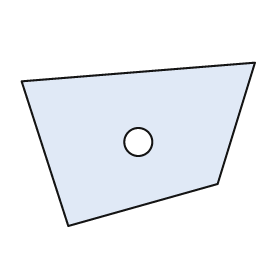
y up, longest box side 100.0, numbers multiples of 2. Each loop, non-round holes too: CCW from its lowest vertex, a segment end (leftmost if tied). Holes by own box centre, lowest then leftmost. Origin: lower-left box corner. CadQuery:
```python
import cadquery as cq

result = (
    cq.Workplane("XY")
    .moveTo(20.0, 0.0)
    .lineTo(84.0, 18.0)
    .lineTo(100.0, 70.0)
    .lineTo(0.0, 62.0)
    .close()
    .moveTo(50.0, 36.0)
    .circle(6.0)
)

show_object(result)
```